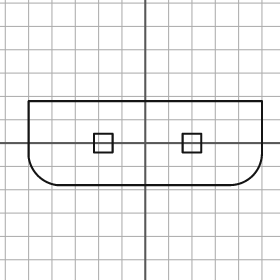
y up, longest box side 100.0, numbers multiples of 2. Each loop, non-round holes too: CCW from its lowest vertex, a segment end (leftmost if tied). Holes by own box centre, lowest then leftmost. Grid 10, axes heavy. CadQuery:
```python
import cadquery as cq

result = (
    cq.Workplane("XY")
    .moveTo(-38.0, -18.0)
    .lineTo(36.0, -18.0)
    .threePointArc((46.0, -14.0), (50.0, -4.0))
    .lineTo(50.0, 18.0)
    .lineTo(-50.0, 18.0)
    .lineTo(-50.0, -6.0)
    .threePointArc((-46.0, -14.0), (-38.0, -18.0))
    .close()
    .moveTo(-22.0, -4.0)
    .lineTo(-14.0, -4.0)
    .lineTo(-14.0, 4.0)
    .lineTo(-22.0, 4.0)
    .close()
    .moveTo(16.0, -4.0)
    .lineTo(24.0, -4.0)
    .lineTo(24.0, 4.0)
    .lineTo(16.0, 4.0)
    .close()
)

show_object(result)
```